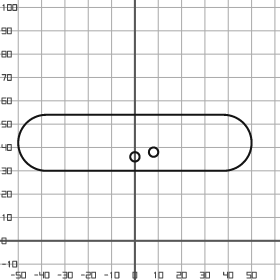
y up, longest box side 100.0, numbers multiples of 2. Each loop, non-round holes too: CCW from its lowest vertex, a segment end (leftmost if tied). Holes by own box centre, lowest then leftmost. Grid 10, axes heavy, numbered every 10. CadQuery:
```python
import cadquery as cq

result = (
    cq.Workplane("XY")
    .moveTo(-38.0, 30.0)
    .lineTo(38.0, 30.0)
    .threePointArc((50.0, 42.0), (38.0, 54.0))
    .lineTo(-38.0, 54.0)
    .threePointArc((-50.0, 42.0), (-38.0, 30.0))
    .close()
    .moveTo(0.0, 36.0)
    .circle(2.0)
    .moveTo(8.0, 38.0)
    .circle(2.0)
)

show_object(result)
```